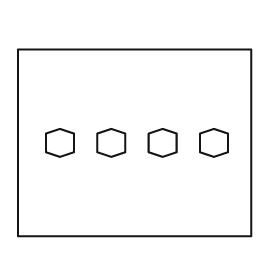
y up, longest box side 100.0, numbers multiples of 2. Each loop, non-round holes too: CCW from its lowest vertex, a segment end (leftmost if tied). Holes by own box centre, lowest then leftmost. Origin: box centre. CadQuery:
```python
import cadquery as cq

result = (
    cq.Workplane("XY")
    .moveTo(-50.0, -40.0)
    .lineTo(50.0, -40.0)
    .lineTo(50.0, 40.0)
    .lineTo(-50.0, 40.0)
    .close()
    .moveTo(-32.0, -6.0)
    .lineTo(-26.0, -4.0)
    .lineTo(-26.0, 4.0)
    .lineTo(-32.0, 6.0)
    .lineTo(-38.0, 4.0)
    .lineTo(-38.0, -4.0)
    .close()
    .moveTo(-10.0, -6.0)
    .lineTo(-4.0, -4.0)
    .lineTo(-4.0, 4.0)
    .lineTo(-10.0, 6.0)
    .lineTo(-16.0, 4.0)
    .lineTo(-16.0, -4.0)
    .close()
    .moveTo(12.0, -6.0)
    .lineTo(18.0, -4.0)
    .lineTo(18.0, 4.0)
    .lineTo(12.0, 6.0)
    .lineTo(6.0, 4.0)
    .lineTo(6.0, -4.0)
    .close()
    .moveTo(34.0, -6.0)
    .lineTo(40.0, -4.0)
    .lineTo(40.0, 4.0)
    .lineTo(34.0, 6.0)
    .lineTo(28.0, 4.0)
    .lineTo(28.0, -4.0)
    .close()
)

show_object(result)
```